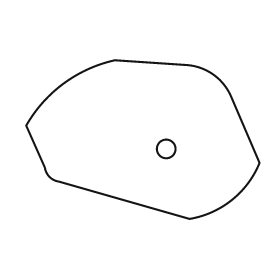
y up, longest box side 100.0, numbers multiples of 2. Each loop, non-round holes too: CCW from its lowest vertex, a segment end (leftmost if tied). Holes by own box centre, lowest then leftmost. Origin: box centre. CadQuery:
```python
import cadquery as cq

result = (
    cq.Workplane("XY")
    .moveTo(20.0, -34.0)
    .threePointArc((38.0, -26.0), (50.0, -10.0))
    .lineTo(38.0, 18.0)
    .threePointArc((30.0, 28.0), (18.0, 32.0))
    .lineTo(-12.0, 34.0)
    .threePointArc((-34.0, 24.0), (-50.0, 6.0))
    .lineTo(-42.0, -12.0)
    .threePointArc((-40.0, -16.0), (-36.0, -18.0))
    .close()
    .moveTo(10.0, -4.0)
    .circle(4.0)
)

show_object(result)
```